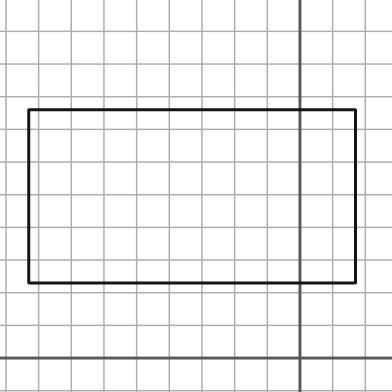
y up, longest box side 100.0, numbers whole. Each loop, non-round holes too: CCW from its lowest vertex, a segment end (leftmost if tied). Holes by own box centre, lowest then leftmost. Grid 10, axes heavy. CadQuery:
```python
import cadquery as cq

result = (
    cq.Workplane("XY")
    .moveTo(-83.0, 23.0)
    .lineTo(17.0, 23.0)
    .lineTo(17.0, 76.0)
    .lineTo(-83.0, 76.0)
    .close()
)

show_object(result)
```